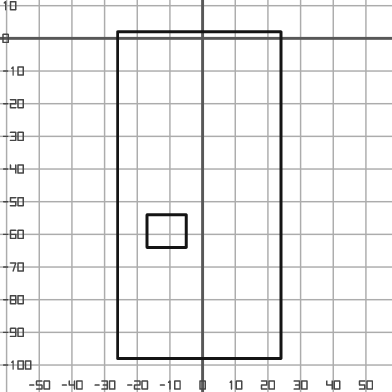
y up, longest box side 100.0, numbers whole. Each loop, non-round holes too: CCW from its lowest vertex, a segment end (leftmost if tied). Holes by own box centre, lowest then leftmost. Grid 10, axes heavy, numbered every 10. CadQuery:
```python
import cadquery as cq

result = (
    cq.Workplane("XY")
    .moveTo(-26.0, -98.0)
    .lineTo(24.0, -98.0)
    .lineTo(24.0, 2.0)
    .lineTo(-26.0, 2.0)
    .close()
    .moveTo(-17.0, -64.0)
    .lineTo(-5.0, -64.0)
    .lineTo(-5.0, -54.0)
    .lineTo(-17.0, -54.0)
    .close()
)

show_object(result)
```